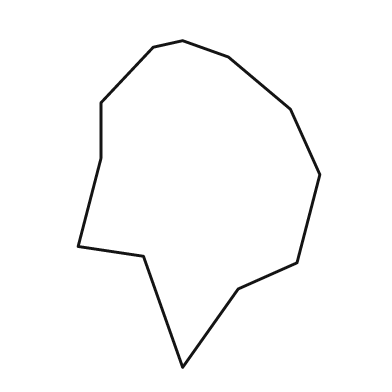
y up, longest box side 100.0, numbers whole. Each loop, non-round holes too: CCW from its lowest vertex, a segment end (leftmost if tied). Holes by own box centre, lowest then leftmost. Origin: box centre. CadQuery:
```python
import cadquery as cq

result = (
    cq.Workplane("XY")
    .moveTo(-5.0, -50.0)
    .lineTo(12.0, -26.0)
    .lineTo(30.0, -18.0)
    .lineTo(37.0, 9.0)
    .lineTo(28.0, 29.0)
    .lineTo(9.0, 45.0)
    .lineTo(-5.0, 50.0)
    .lineTo(-14.0, 48.0)
    .lineTo(-30.0, 31.0)
    .lineTo(-30.0, 14.0)
    .lineTo(-37.0, -13.0)
    .lineTo(-17.0, -16.0)
    .close()
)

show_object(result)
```